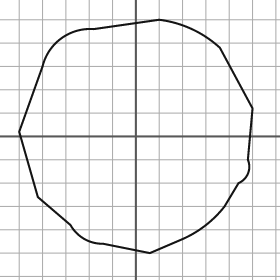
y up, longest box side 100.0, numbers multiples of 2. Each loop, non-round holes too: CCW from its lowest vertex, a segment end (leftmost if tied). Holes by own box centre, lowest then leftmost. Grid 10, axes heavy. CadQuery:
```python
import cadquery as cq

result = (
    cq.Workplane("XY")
    .moveTo(6.0, -50.0)
    .lineTo(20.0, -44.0)
    .threePointArc((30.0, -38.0), (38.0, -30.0))
    .lineTo(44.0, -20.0)
    .threePointArc((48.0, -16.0), (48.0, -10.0))
    .lineTo(50.0, 12.0)
    .lineTo(36.0, 38.0)
    .threePointArc((24.0, 46.0), (10.0, 50.0))
    .lineTo(-18.0, 46.0)
    .threePointArc((-32.0, 42.0), (-40.0, 30.0))
    .lineTo(-50.0, 2.0)
    .lineTo(-42.0, -26.0)
    .lineTo(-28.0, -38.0)
    .threePointArc((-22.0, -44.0), (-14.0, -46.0))
    .close()
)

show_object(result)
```